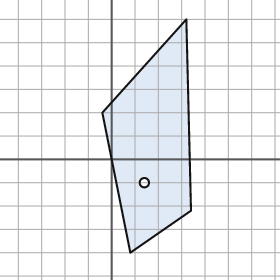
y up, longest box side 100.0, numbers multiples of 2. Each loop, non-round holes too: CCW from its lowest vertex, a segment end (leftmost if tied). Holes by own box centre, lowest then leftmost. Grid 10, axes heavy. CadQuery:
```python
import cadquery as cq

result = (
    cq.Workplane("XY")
    .moveTo(8.0, -40.0)
    .lineTo(34.0, -22.0)
    .lineTo(32.0, 60.0)
    .lineTo(-4.0, 20.0)
    .close()
    .moveTo(14.0, -10.0)
    .circle(2.0)
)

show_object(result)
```